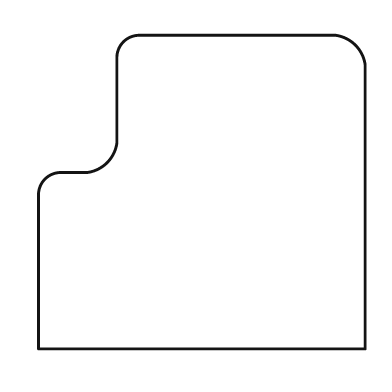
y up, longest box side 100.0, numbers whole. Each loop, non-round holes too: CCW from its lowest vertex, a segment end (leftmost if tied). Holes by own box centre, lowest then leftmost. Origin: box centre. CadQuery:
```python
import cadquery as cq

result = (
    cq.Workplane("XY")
    .moveTo(-50.0, -48.0)
    .lineTo(50.0, -48.0)
    .lineTo(50.0, 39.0)
    .threePointArc((47.0, 45.0), (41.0, 48.0))
    .lineTo(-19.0, 48.0)
    .threePointArc((-24.0, 46.0), (-26.0, 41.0))
    .lineTo(-26.0, 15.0)
    .threePointArc((-29.0, 9.0), (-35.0, 6.0))
    .lineTo(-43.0, 6.0)
    .threePointArc((-48.0, 4.0), (-50.0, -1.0))
    .close()
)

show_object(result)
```